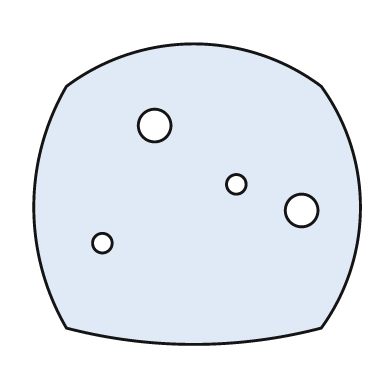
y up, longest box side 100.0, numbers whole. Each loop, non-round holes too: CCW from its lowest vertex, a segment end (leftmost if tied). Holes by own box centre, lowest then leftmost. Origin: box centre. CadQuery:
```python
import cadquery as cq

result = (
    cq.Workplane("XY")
    .moveTo(-40.0, -41.0)
    .threePointArc((-1.0, -46.0), (38.0, -41.0))
    .threePointArc((50.0, -4.0), (38.0, 33.0))
    .threePointArc((-1.0, 46.0), (-40.0, 33.0))
    .threePointArc((-50.0, -4.0), (-40.0, -41.0))
    .close()
    .moveTo(-29.0, -15.0)
    .circle(3.0)
    .moveTo(32.0, -5.0)
    .circle(5.0)
    .moveTo(12.0, 3.0)
    .circle(3.0)
    .moveTo(-13.0, 21.0)
    .circle(5.0)
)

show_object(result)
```